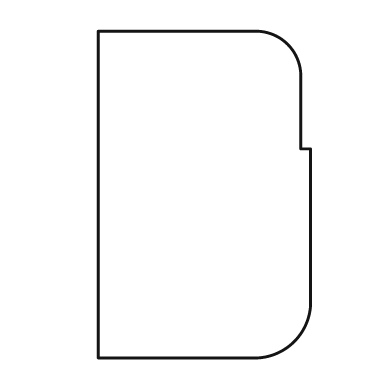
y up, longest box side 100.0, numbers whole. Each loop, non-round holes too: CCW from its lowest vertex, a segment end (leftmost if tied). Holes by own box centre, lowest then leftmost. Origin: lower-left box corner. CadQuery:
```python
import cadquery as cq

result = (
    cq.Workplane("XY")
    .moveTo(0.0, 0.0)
    .lineTo(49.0, 0.0)
    .threePointArc((60.0, 5.0), (65.0, 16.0))
    .lineTo(65.0, 64.0)
    .lineTo(62.0, 64.0)
    .lineTo(62.0, 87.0)
    .threePointArc((58.0, 96.0), (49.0, 100.0))
    .lineTo(0.0, 100.0)
    .close()
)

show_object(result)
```